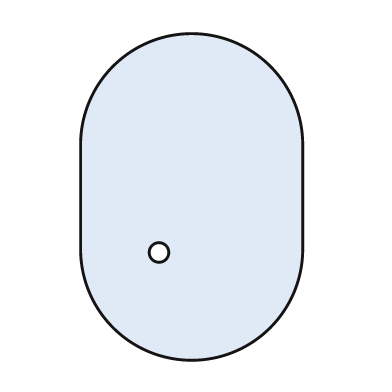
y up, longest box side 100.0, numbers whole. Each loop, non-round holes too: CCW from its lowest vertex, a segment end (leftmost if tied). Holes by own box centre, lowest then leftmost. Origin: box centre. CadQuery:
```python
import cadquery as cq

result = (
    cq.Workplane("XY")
    .moveTo(-34.0, -16.0)
    .threePointArc((0.0, -50.0), (34.0, -16.0))
    .lineTo(34.0, 16.0)
    .threePointArc((0.0, 50.0), (-34.0, 16.0))
    .close()
    .moveTo(-10.0, -17.0)
    .circle(3.0)
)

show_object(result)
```